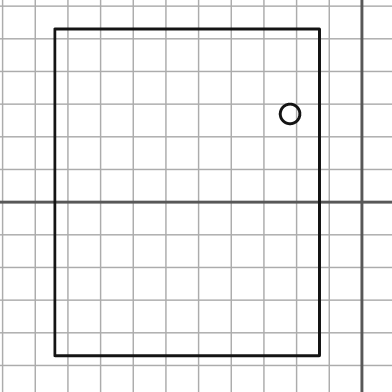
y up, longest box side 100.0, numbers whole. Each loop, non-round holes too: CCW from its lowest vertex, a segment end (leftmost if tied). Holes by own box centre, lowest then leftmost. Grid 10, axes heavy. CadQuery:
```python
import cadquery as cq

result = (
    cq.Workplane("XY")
    .moveTo(-94.0, -47.0)
    .lineTo(-13.0, -47.0)
    .lineTo(-13.0, 53.0)
    .lineTo(-94.0, 53.0)
    .close()
    .moveTo(-22.0, 27.0)
    .circle(3.0)
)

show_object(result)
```